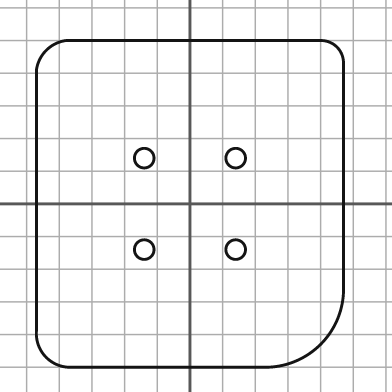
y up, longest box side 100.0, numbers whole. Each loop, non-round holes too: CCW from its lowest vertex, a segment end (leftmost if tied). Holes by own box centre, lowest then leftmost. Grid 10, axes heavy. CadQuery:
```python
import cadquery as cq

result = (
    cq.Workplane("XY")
    .moveTo(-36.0, -50.0)
    .lineTo(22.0, -50.0)
    .threePointArc((40.0, -43.0), (47.0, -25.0))
    .lineTo(47.0, 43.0)
    .threePointArc((45.0, 48.0), (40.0, 50.0))
    .lineTo(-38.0, 50.0)
    .threePointArc((-44.0, 47.0), (-47.0, 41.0))
    .lineTo(-47.0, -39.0)
    .threePointArc((-44.0, -47.0), (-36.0, -50.0))
    .close()
    .moveTo(-14.0, -14.0)
    .circle(3.0)
    .moveTo(14.0, -14.0)
    .circle(3.0)
    .moveTo(-14.0, 14.0)
    .circle(3.0)
    .moveTo(14.0, 14.0)
    .circle(3.0)
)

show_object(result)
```